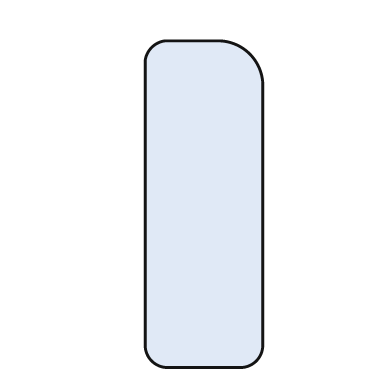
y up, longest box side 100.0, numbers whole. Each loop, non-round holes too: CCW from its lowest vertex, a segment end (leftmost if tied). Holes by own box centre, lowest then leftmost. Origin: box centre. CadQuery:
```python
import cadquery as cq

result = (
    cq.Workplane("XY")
    .moveTo(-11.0, -50.0)
    .lineTo(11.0, -50.0)
    .threePointArc((16.0, -48.0), (18.0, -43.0))
    .lineTo(18.0, 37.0)
    .threePointArc((14.0, 46.0), (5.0, 50.0))
    .lineTo(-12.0, 50.0)
    .threePointArc((-16.0, 48.0), (-18.0, 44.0))
    .lineTo(-18.0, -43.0)
    .threePointArc((-16.0, -48.0), (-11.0, -50.0))
    .close()
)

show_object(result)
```